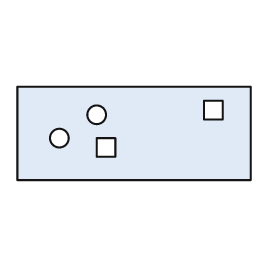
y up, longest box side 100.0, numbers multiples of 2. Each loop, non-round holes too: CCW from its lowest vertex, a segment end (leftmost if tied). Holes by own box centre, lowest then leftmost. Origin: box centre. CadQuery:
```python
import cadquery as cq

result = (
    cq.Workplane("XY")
    .moveTo(-50.0, -20.0)
    .lineTo(50.0, -20.0)
    .lineTo(50.0, 20.0)
    .lineTo(-50.0, 20.0)
    .close()
    .moveTo(-16.0, -10.0)
    .lineTo(-8.0, -10.0)
    .lineTo(-8.0, -2.0)
    .lineTo(-16.0, -2.0)
    .close()
    .moveTo(-32.0, -2.0)
    .circle(4.0)
    .moveTo(-16.0, 8.0)
    .circle(4.0)
    .moveTo(30.0, 6.0)
    .lineTo(38.0, 6.0)
    .lineTo(38.0, 14.0)
    .lineTo(30.0, 14.0)
    .close()
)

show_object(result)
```